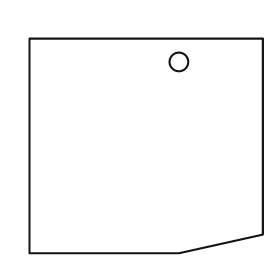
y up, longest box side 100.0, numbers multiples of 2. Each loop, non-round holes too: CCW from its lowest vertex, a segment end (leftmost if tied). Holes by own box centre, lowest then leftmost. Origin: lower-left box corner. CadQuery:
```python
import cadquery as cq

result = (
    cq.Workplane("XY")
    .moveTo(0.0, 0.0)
    .lineTo(64.0, 0.0)
    .lineTo(100.0, 8.0)
    .lineTo(100.0, 92.0)
    .lineTo(0.0, 92.0)
    .close()
    .moveTo(64.0, 82.0)
    .circle(4.0)
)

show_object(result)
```